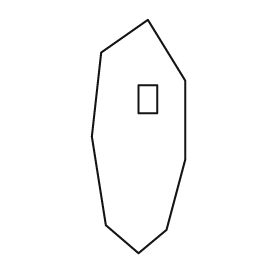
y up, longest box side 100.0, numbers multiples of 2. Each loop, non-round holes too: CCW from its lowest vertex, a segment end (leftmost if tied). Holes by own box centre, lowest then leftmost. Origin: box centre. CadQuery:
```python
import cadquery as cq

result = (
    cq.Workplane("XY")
    .moveTo(0.0, -50.0)
    .lineTo(12.0, -40.0)
    .lineTo(20.0, -10.0)
    .lineTo(20.0, 24.0)
    .lineTo(4.0, 50.0)
    .lineTo(-16.0, 36.0)
    .lineTo(-20.0, 0.0)
    .lineTo(-14.0, -38.0)
    .close()
    .moveTo(0.0, 10.0)
    .lineTo(8.0, 10.0)
    .lineTo(8.0, 22.0)
    .lineTo(0.0, 22.0)
    .close()
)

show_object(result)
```